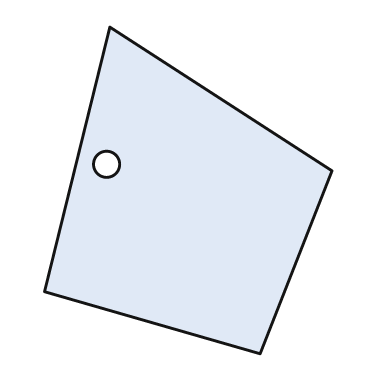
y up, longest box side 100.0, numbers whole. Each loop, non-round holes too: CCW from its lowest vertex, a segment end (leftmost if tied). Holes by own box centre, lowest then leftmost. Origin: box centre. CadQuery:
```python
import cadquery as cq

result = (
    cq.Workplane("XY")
    .moveTo(22.0, -50.0)
    .lineTo(44.0, 6.0)
    .lineTo(-24.0, 50.0)
    .lineTo(-44.0, -31.0)
    .close()
    .moveTo(-25.0, 8.0)
    .circle(4.0)
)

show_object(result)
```